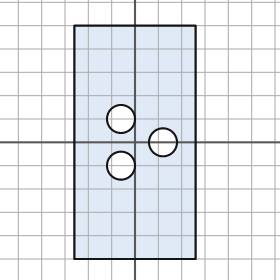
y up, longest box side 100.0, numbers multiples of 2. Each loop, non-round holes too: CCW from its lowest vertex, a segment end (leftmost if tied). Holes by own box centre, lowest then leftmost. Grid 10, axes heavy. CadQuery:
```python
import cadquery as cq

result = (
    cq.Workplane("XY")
    .moveTo(-26.0, -50.0)
    .lineTo(26.0, -50.0)
    .lineTo(26.0, 50.0)
    .lineTo(-26.0, 50.0)
    .close()
    .moveTo(-6.0, -10.0)
    .circle(6.0)
    .moveTo(12.0, 0.0)
    .circle(6.0)
    .moveTo(-6.0, 10.0)
    .circle(6.0)
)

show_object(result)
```